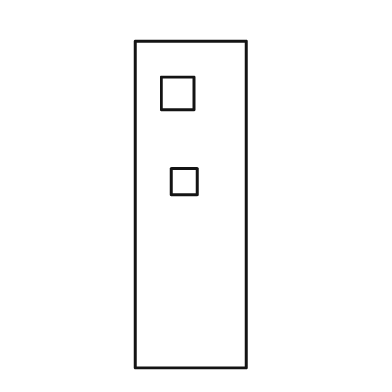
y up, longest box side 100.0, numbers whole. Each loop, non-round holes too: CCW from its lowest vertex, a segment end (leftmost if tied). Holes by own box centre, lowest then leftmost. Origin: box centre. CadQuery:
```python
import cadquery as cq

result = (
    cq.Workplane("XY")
    .moveTo(-17.0, -50.0)
    .lineTo(17.0, -50.0)
    .lineTo(17.0, 50.0)
    .lineTo(-17.0, 50.0)
    .close()
    .moveTo(-6.0, 3.0)
    .lineTo(2.0, 3.0)
    .lineTo(2.0, 11.0)
    .lineTo(-6.0, 11.0)
    .close()
    .moveTo(-9.0, 29.0)
    .lineTo(1.0, 29.0)
    .lineTo(1.0, 39.0)
    .lineTo(-9.0, 39.0)
    .close()
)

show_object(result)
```